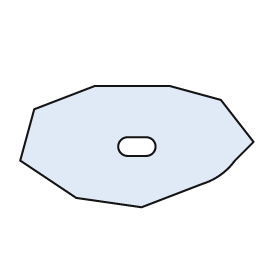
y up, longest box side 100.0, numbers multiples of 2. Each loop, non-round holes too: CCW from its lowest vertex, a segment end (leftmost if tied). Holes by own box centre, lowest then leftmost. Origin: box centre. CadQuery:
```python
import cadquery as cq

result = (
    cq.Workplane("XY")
    .moveTo(2.0, -26.0)
    .lineTo(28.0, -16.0)
    .threePointArc((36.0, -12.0), (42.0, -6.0))
    .lineTo(50.0, 2.0)
    .lineTo(36.0, 20.0)
    .lineTo(14.0, 26.0)
    .lineTo(-18.0, 26.0)
    .lineTo(-44.0, 16.0)
    .lineTo(-50.0, -6.0)
    .lineTo(-26.0, -22.0)
    .close()
    .moveTo(-4.0, -4.0)
    .lineTo(4.0, -4.0)
    .threePointArc((8.0, 0.0), (4.0, 4.0))
    .lineTo(-4.0, 4.0)
    .threePointArc((-8.0, 0.0), (-4.0, -4.0))
    .close()
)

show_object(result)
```